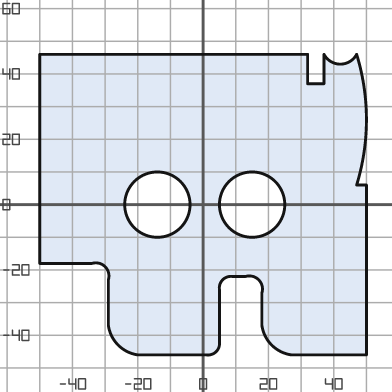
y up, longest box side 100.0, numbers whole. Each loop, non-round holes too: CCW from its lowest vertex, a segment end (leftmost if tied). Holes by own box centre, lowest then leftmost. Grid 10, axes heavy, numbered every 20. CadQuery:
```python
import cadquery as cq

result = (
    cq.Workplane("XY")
    .moveTo(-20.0, -46.0)
    .lineTo(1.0, -46.0)
    .threePointArc((4.0, -45.0), (5.0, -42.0))
    .lineTo(5.0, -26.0)
    .threePointArc((6.0, -23.0), (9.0, -22.0))
    .lineTo(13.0, -22.0)
    .threePointArc((17.0, -23.0), (18.0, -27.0))
    .lineTo(18.0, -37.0)
    .threePointArc((21.0, -43.0), (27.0, -46.0))
    .lineTo(50.0, -46.0)
    .lineTo(50.0, 6.0)
    .lineTo(47.0, 6.0)
    .threePointArc((50.0, 26.0), (47.0, 46.0))
    .threePointArc((42.0, 43.0), (37.0, 46.0))
    .lineTo(37.0, 37.0)
    .lineTo(32.0, 37.0)
    .lineTo(32.0, 46.0)
    .lineTo(-50.0, 46.0)
    .lineTo(-50.0, -18.0)
    .lineTo(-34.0, -18.0)
    .threePointArc((-30.0, -19.0), (-29.0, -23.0))
    .lineTo(-29.0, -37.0)
    .threePointArc((-26.0, -43.0), (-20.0, -46.0))
    .close()
    .moveTo(-14.0, 0.0)
    .circle(10.0)
    .moveTo(15.0, 0.0)
    .circle(10.0)
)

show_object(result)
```